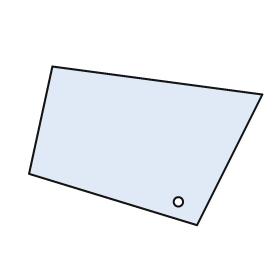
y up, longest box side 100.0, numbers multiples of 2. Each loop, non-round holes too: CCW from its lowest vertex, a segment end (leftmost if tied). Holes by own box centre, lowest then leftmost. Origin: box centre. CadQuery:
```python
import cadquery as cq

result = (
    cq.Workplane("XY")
    .moveTo(22.0, -34.0)
    .lineTo(50.0, 22.0)
    .lineTo(-40.0, 34.0)
    .lineTo(-50.0, -12.0)
    .close()
    .moveTo(14.0, -24.0)
    .circle(2.0)
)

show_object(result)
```